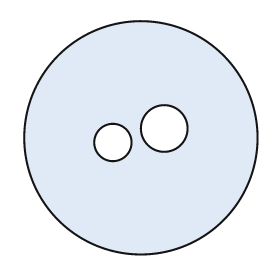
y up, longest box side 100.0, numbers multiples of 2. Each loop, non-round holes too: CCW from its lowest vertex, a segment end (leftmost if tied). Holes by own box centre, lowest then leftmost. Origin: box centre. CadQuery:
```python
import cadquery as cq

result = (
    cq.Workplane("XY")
    .moveTo(0.0, 0.0)
    .circle(50.0)
    .moveTo(-12.0, -2.0)
    .circle(8.0)
    .moveTo(10.0, 4.0)
    .circle(10.0)
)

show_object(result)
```